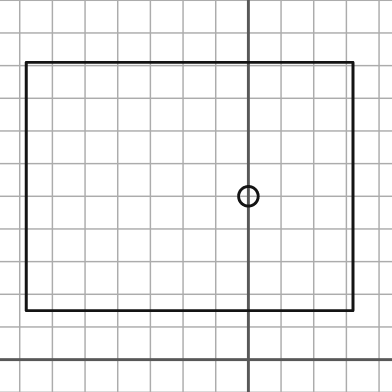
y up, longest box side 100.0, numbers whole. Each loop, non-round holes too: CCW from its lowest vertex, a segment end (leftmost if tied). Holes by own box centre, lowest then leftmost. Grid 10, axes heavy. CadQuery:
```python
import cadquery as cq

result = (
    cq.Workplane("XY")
    .moveTo(-68.0, 15.0)
    .lineTo(32.0, 15.0)
    .lineTo(32.0, 91.0)
    .lineTo(-68.0, 91.0)
    .close()
    .moveTo(0.0, 50.0)
    .circle(3.0)
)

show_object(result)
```